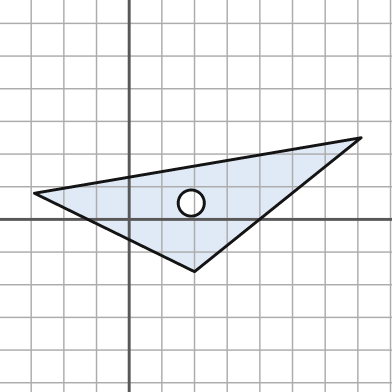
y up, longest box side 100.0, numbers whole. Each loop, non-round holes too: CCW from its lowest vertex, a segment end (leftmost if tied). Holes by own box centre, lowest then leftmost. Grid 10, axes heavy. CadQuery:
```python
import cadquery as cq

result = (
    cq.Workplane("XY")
    .moveTo(20.0, -16.0)
    .lineTo(71.0, 25.0)
    .lineTo(-29.0, 8.0)
    .close()
    .moveTo(19.0, 5.0)
    .circle(4.0)
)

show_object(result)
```